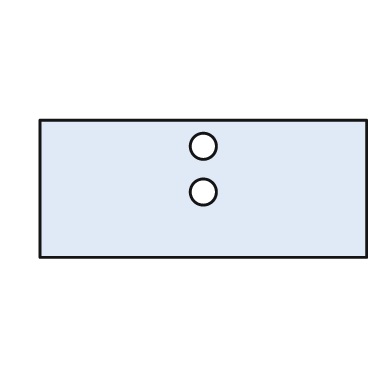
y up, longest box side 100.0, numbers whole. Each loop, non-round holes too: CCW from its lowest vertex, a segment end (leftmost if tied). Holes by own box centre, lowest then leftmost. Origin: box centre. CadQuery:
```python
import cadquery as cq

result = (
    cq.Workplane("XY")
    .moveTo(-50.0, -21.0)
    .lineTo(50.0, -21.0)
    .lineTo(50.0, 21.0)
    .lineTo(-50.0, 21.0)
    .close()
    .moveTo(0.0, -1.0)
    .circle(4.0)
    .moveTo(0.0, 13.0)
    .circle(4.0)
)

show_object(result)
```